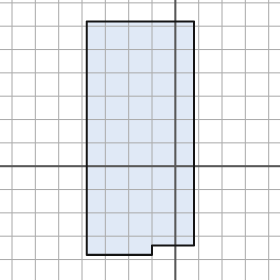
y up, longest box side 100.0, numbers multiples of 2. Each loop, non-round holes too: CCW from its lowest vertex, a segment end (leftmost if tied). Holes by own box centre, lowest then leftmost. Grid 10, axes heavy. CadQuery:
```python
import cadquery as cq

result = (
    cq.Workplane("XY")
    .moveTo(-38.0, -38.0)
    .lineTo(-10.0, -38.0)
    .lineTo(-10.0, -34.0)
    .lineTo(8.0, -34.0)
    .lineTo(8.0, 62.0)
    .lineTo(-38.0, 62.0)
    .close()
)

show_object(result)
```